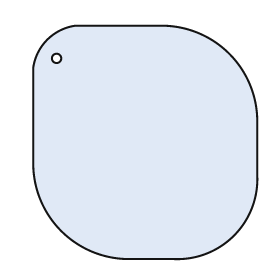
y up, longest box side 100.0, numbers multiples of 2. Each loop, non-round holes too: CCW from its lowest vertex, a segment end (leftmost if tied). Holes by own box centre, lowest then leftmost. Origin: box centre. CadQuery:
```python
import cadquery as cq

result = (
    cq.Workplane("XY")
    .moveTo(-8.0, -50.0)
    .lineTo(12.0, -50.0)
    .threePointArc((38.0, -40.0), (48.0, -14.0))
    .lineTo(48.0, 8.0)
    .threePointArc((36.0, 38.0), (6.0, 50.0))
    .lineTo(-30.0, 50.0)
    .threePointArc((-42.0, 44.0), (-48.0, 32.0))
    .lineTo(-48.0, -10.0)
    .threePointArc((-36.0, -38.0), (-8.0, -50.0))
    .close()
    .moveTo(-38.0, 36.0)
    .circle(2.0)
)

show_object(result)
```